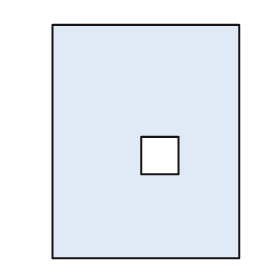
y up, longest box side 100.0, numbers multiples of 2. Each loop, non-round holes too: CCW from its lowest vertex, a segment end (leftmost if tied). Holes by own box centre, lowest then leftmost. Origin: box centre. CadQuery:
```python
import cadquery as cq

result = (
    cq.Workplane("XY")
    .moveTo(-40.0, -50.0)
    .lineTo(40.0, -50.0)
    .lineTo(40.0, 50.0)
    .lineTo(-40.0, 50.0)
    .close()
    .moveTo(-2.0, -14.0)
    .lineTo(14.0, -14.0)
    .lineTo(14.0, 2.0)
    .lineTo(-2.0, 2.0)
    .close()
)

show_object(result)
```